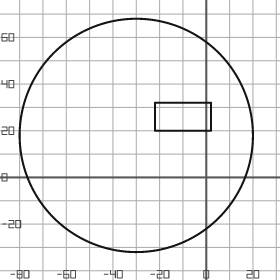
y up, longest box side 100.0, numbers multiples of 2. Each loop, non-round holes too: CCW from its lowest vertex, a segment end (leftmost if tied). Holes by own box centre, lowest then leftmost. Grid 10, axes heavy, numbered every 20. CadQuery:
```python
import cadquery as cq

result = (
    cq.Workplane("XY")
    .moveTo(-30.0, 18.0)
    .circle(50.0)
    .moveTo(-22.0, 20.0)
    .lineTo(2.0, 20.0)
    .lineTo(2.0, 32.0)
    .lineTo(-22.0, 32.0)
    .close()
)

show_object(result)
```